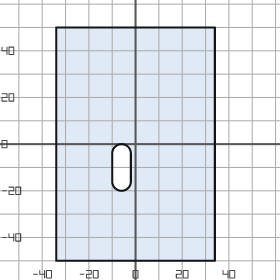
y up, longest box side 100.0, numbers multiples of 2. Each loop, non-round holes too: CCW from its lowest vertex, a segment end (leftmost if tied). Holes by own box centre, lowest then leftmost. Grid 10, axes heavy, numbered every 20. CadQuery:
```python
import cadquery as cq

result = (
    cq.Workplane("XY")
    .moveTo(-34.0, -50.0)
    .lineTo(34.0, -50.0)
    .lineTo(34.0, 50.0)
    .lineTo(-34.0, 50.0)
    .close()
    .moveTo(-10.0, -16.0)
    .threePointArc((-6.0, -20.0), (-2.0, -16.0))
    .lineTo(-2.0, -4.0)
    .threePointArc((-6.0, 0.0), (-10.0, -4.0))
    .close()
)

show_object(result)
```